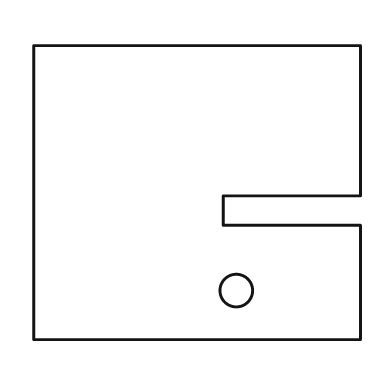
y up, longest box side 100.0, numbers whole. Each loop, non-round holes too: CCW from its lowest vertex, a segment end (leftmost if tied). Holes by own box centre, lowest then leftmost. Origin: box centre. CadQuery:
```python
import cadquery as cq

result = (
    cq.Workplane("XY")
    .moveTo(-50.0, -45.0)
    .lineTo(50.0, -45.0)
    .lineTo(50.0, -10.0)
    .lineTo(8.0, -10.0)
    .lineTo(8.0, -1.0)
    .lineTo(50.0, -1.0)
    .lineTo(50.0, 45.0)
    .lineTo(-50.0, 45.0)
    .close()
    .moveTo(12.0, -30.0)
    .circle(5.0)
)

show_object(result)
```